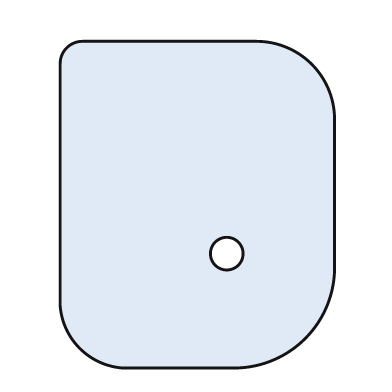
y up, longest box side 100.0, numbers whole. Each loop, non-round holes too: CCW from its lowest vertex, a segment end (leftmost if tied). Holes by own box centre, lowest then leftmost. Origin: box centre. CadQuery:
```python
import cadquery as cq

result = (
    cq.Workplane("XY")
    .moveTo(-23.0, -50.0)
    .lineTo(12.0, -50.0)
    .threePointArc((33.0, -41.0), (42.0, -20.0))
    .lineTo(42.0, 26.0)
    .threePointArc((35.0, 43.0), (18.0, 50.0))
    .lineTo(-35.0, 50.0)
    .threePointArc((-40.0, 48.0), (-42.0, 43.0))
    .lineTo(-42.0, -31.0)
    .threePointArc((-36.0, -44.0), (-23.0, -50.0))
    .close()
    .moveTo(9.0, -15.0)
    .circle(5.0)
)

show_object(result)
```